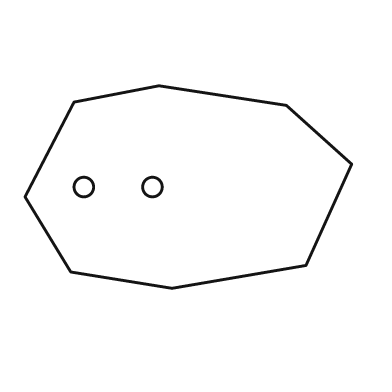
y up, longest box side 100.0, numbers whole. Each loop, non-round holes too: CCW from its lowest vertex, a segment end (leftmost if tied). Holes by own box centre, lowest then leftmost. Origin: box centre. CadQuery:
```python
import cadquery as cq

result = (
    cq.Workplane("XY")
    .moveTo(-5.0, -31.0)
    .lineTo(36.0, -24.0)
    .lineTo(50.0, 7.0)
    .lineTo(30.0, 25.0)
    .lineTo(-9.0, 31.0)
    .lineTo(-35.0, 26.0)
    .lineTo(-50.0, -3.0)
    .lineTo(-36.0, -26.0)
    .close()
    .moveTo(-32.0, 0.0)
    .circle(3.0)
    .moveTo(-11.0, 0.0)
    .circle(3.0)
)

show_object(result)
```